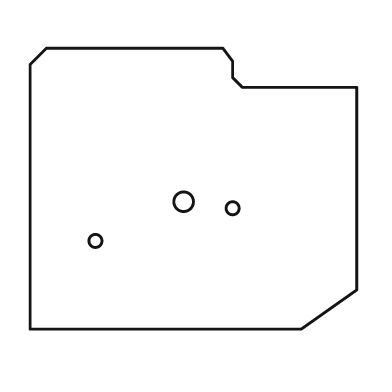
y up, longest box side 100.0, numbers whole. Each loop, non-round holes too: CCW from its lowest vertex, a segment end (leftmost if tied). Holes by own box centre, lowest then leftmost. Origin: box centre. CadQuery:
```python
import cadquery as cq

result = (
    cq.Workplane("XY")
    .moveTo(-50.0, -43.0)
    .lineTo(33.0, -43.0)
    .lineTo(50.0, -31.0)
    .lineTo(50.0, 31.0)
    .lineTo(15.0, 31.0)
    .lineTo(12.0, 34.0)
    .lineTo(12.0, 39.0)
    .lineTo(9.0, 43.0)
    .lineTo(-45.0, 43.0)
    .lineTo(-50.0, 38.0)
    .close()
    .moveTo(-30.0, -16.0)
    .circle(2.0)
    .moveTo(12.0, -6.0)
    .circle(2.0)
    .moveTo(-3.0, -4.0)
    .circle(3.0)
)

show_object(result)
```